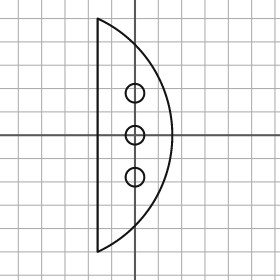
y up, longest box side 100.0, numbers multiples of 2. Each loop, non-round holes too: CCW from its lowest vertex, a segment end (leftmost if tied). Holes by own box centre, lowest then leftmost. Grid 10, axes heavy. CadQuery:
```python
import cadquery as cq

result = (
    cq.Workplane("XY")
    .moveTo(-16.0, -50.0)
    .threePointArc((16.0, 0.0), (-16.0, 50.0))
    .close()
    .moveTo(0.0, -18.0)
    .circle(4.0)
    .moveTo(0.0, 0.0)
    .circle(4.0)
    .moveTo(0.0, 18.0)
    .circle(4.0)
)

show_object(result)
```